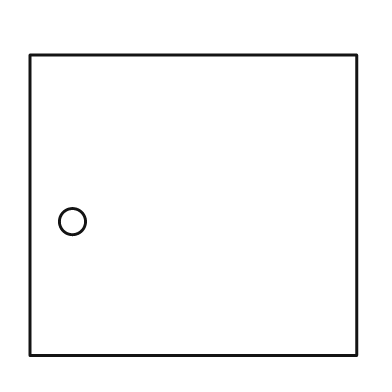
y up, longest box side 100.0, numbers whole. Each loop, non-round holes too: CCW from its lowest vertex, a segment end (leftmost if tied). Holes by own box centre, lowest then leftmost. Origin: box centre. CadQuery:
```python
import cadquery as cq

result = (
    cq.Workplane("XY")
    .moveTo(-50.0, -46.0)
    .lineTo(50.0, -46.0)
    .lineTo(50.0, 46.0)
    .lineTo(-50.0, 46.0)
    .close()
    .moveTo(-37.0, -5.0)
    .circle(4.0)
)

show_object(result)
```